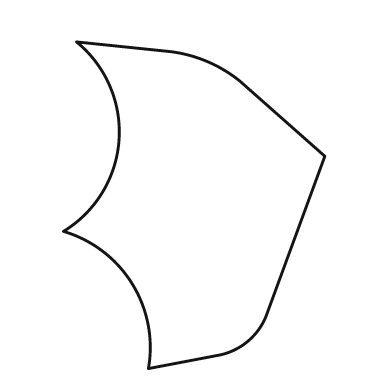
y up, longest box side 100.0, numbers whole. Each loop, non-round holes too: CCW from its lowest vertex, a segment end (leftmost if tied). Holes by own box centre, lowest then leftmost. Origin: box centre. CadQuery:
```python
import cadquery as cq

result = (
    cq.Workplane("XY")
    .moveTo(-14.0, -50.0)
    .lineTo(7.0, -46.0)
    .threePointArc((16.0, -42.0), (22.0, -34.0))
    .lineTo(40.0, 15.0)
    .lineTo(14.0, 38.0)
    .threePointArc((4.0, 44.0), (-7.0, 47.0))
    .lineTo(-36.0, 50.0)
    .threePointArc((-23.0, 20.0), (-40.0, -8.0))
    .threePointArc((-19.0, -24.0), (-14.0, -50.0))
    .close()
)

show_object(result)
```